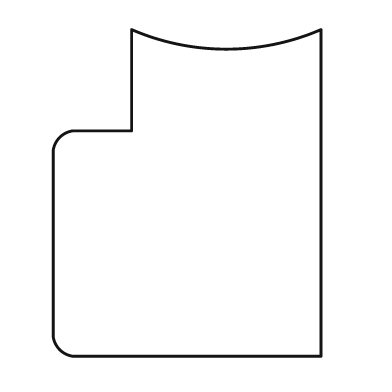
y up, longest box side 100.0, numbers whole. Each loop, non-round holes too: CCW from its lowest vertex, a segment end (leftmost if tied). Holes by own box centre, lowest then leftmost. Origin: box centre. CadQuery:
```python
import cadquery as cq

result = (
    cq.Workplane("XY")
    .moveTo(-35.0, -50.0)
    .lineTo(41.0, -50.0)
    .lineTo(41.0, 50.0)
    .threePointArc((12.0, 44.0), (-17.0, 50.0))
    .lineTo(-17.0, 19.0)
    .lineTo(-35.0, 19.0)
    .threePointArc((-39.0, 17.0), (-41.0, 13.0))
    .lineTo(-41.0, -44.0)
    .threePointArc((-39.0, -48.0), (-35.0, -50.0))
    .close()
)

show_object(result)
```